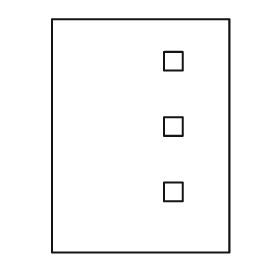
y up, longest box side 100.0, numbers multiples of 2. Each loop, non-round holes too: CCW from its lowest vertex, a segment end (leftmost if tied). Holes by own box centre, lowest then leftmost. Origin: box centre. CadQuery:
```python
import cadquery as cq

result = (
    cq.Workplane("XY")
    .moveTo(-38.0, -50.0)
    .lineTo(38.0, -50.0)
    .lineTo(38.0, 50.0)
    .lineTo(-38.0, 50.0)
    .close()
    .moveTo(10.0, -28.0)
    .lineTo(18.0, -28.0)
    .lineTo(18.0, -20.0)
    .lineTo(10.0, -20.0)
    .close()
    .moveTo(10.0, 0.0)
    .lineTo(18.0, 0.0)
    .lineTo(18.0, 8.0)
    .lineTo(10.0, 8.0)
    .close()
    .moveTo(10.0, 28.0)
    .lineTo(18.0, 28.0)
    .lineTo(18.0, 36.0)
    .lineTo(10.0, 36.0)
    .close()
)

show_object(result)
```